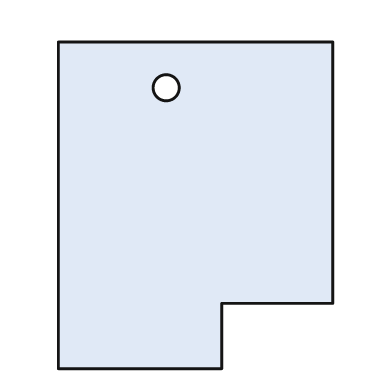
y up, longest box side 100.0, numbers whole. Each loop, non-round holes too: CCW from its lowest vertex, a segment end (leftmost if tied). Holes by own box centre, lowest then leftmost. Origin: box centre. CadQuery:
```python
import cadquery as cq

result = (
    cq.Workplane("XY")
    .moveTo(-42.0, -50.0)
    .lineTo(8.0, -50.0)
    .lineTo(8.0, -30.0)
    .lineTo(42.0, -30.0)
    .lineTo(42.0, 50.0)
    .lineTo(-42.0, 50.0)
    .close()
    .moveTo(-9.0, 36.0)
    .circle(4.0)
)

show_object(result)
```